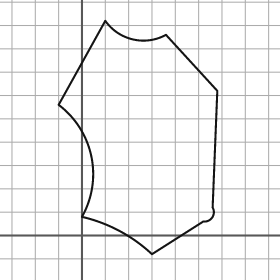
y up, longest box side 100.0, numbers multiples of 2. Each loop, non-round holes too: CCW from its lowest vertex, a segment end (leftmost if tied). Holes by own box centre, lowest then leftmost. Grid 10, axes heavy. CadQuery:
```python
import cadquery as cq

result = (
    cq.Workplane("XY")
    .moveTo(30.0, -8.0)
    .lineTo(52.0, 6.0)
    .threePointArc((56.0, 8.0), (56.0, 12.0))
    .lineTo(58.0, 62.0)
    .lineTo(36.0, 86.0)
    .threePointArc((22.0, 84.0), (10.0, 92.0))
    .lineTo(-10.0, 56.0)
    .threePointArc((4.0, 34.0), (0.0, 8.0))
    .threePointArc((16.0, 2.0), (30.0, -8.0))
    .close()
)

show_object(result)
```